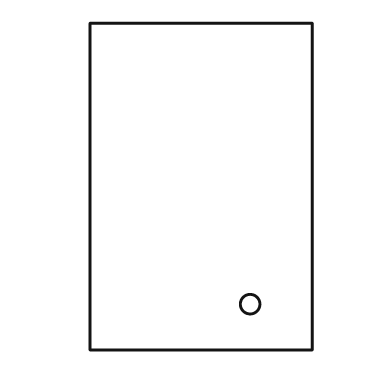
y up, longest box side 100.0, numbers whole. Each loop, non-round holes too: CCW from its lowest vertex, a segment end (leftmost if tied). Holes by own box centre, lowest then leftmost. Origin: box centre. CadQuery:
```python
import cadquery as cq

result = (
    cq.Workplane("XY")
    .moveTo(-34.0, -50.0)
    .lineTo(34.0, -50.0)
    .lineTo(34.0, 50.0)
    .lineTo(-34.0, 50.0)
    .close()
    .moveTo(15.0, -36.0)
    .circle(3.0)
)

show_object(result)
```